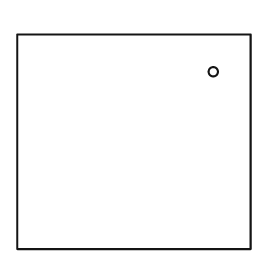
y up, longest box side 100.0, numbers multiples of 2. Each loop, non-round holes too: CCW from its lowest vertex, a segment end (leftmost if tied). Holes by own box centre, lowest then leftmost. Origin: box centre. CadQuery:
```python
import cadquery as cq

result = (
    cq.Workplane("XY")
    .moveTo(-50.0, -46.0)
    .lineTo(50.0, -46.0)
    .lineTo(50.0, 46.0)
    .lineTo(-50.0, 46.0)
    .close()
    .moveTo(34.0, 30.0)
    .circle(2.0)
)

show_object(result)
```